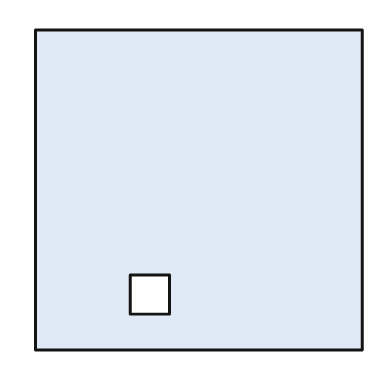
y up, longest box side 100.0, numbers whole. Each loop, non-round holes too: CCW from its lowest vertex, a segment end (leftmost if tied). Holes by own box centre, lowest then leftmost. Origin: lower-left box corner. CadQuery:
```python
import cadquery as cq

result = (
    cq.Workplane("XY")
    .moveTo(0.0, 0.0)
    .lineTo(100.0, 0.0)
    .lineTo(100.0, 98.0)
    .lineTo(0.0, 98.0)
    .close()
    .moveTo(29.0, 11.0)
    .lineTo(41.0, 11.0)
    .lineTo(41.0, 23.0)
    .lineTo(29.0, 23.0)
    .close()
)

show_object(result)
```